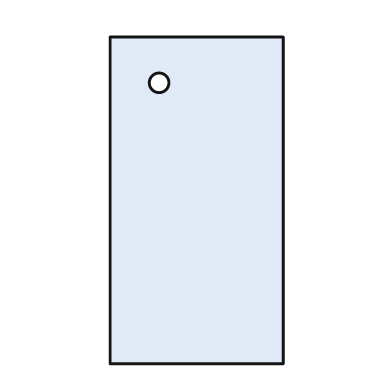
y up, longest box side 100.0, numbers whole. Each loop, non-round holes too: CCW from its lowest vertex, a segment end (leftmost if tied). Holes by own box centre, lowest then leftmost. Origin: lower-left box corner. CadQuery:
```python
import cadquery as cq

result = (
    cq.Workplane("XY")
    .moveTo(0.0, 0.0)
    .lineTo(53.0, 0.0)
    .lineTo(53.0, 100.0)
    .lineTo(0.0, 100.0)
    .close()
    .moveTo(15.0, 86.0)
    .circle(3.0)
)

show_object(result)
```